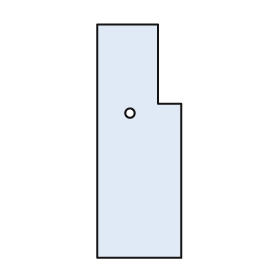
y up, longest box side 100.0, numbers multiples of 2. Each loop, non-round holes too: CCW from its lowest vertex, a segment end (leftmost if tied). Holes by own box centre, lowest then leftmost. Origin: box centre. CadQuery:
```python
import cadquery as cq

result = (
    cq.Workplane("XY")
    .moveTo(-18.0, -50.0)
    .lineTo(18.0, -50.0)
    .lineTo(18.0, 16.0)
    .lineTo(8.0, 16.0)
    .lineTo(8.0, 50.0)
    .lineTo(-18.0, 50.0)
    .close()
    .moveTo(-4.0, 12.0)
    .circle(2.0)
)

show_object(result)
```